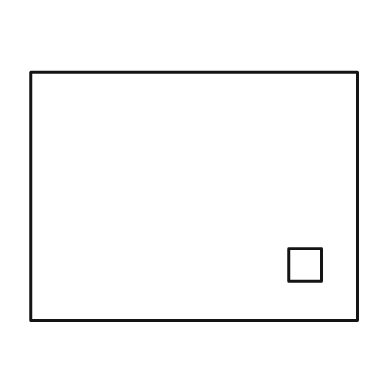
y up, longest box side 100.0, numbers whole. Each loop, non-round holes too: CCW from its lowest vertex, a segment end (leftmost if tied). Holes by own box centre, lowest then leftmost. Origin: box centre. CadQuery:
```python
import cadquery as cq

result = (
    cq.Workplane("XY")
    .moveTo(-50.0, -38.0)
    .lineTo(50.0, -38.0)
    .lineTo(50.0, 38.0)
    .lineTo(-50.0, 38.0)
    .close()
    .moveTo(29.0, -26.0)
    .lineTo(39.0, -26.0)
    .lineTo(39.0, -16.0)
    .lineTo(29.0, -16.0)
    .close()
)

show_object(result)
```